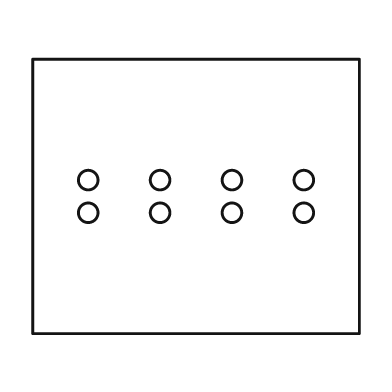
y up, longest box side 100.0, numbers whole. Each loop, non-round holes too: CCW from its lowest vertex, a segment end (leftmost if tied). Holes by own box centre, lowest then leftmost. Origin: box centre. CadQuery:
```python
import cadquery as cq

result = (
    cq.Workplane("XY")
    .moveTo(-50.0, -42.0)
    .lineTo(50.0, -42.0)
    .lineTo(50.0, 42.0)
    .lineTo(-50.0, 42.0)
    .close()
    .moveTo(-33.0, -5.0)
    .circle(3.0)
    .moveTo(-11.0, -5.0)
    .circle(3.0)
    .moveTo(11.0, -5.0)
    .circle(3.0)
    .moveTo(33.0, -5.0)
    .circle(3.0)
    .moveTo(-33.0, 5.0)
    .circle(3.0)
    .moveTo(-11.0, 5.0)
    .circle(3.0)
    .moveTo(11.0, 5.0)
    .circle(3.0)
    .moveTo(33.0, 5.0)
    .circle(3.0)
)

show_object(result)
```